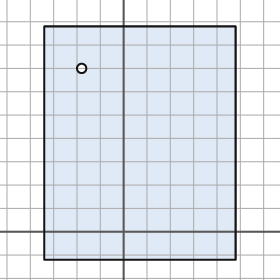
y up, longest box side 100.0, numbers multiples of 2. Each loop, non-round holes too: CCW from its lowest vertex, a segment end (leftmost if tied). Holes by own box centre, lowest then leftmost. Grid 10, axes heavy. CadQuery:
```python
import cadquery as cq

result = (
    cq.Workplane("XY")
    .moveTo(-34.0, -12.0)
    .lineTo(48.0, -12.0)
    .lineTo(48.0, 88.0)
    .lineTo(-34.0, 88.0)
    .close()
    .moveTo(-18.0, 70.0)
    .circle(2.0)
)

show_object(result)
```